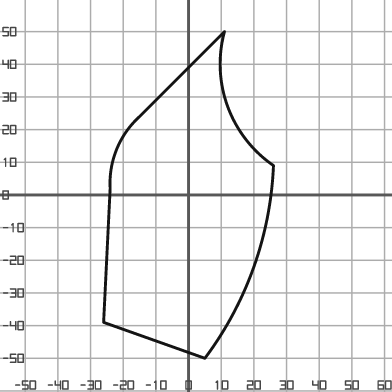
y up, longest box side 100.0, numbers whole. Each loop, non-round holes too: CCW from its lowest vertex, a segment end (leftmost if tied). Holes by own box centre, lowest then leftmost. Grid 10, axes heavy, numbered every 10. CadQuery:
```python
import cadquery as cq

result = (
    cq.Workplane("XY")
    .moveTo(5.0, -50.0)
    .threePointArc((20.0, -22.0), (26.0, 9.0))
    .threePointArc((12.0, 27.0), (11.0, 50.0))
    .lineTo(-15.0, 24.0)
    .threePointArc((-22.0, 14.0), (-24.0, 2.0))
    .lineTo(-26.0, -39.0)
    .close()
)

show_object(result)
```